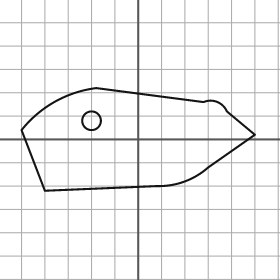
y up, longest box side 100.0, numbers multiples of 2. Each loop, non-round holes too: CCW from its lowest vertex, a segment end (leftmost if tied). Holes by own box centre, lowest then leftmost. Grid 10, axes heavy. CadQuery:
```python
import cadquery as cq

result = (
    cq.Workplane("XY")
    .moveTo(-40.0, -22.0)
    .lineTo(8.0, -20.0)
    .threePointArc((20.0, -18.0), (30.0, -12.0))
    .lineTo(50.0, 2.0)
    .lineTo(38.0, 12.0)
    .threePointArc((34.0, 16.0), (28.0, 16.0))
    .lineTo(-18.0, 22.0)
    .threePointArc((-36.0, 16.0), (-50.0, 4.0))
    .close()
    .moveTo(-20.0, 8.0)
    .circle(4.0)
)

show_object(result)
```